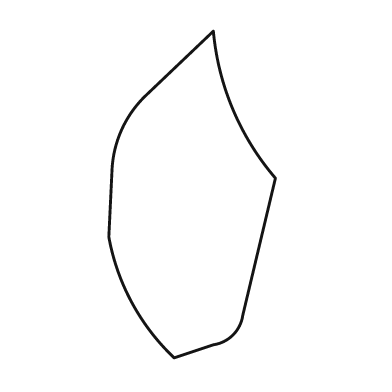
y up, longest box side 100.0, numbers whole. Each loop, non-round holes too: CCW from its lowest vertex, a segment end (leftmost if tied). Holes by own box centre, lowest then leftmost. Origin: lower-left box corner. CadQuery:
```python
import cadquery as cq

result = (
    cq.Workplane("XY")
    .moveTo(20.0, 0.0)
    .lineTo(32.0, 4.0)
    .threePointArc((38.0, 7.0), (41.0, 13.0))
    .lineTo(51.0, 55.0)
    .threePointArc((38.0, 76.0), (32.0, 100.0))
    .lineTo(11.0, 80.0)
    .threePointArc((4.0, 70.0), (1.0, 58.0))
    .lineTo(0.0, 37.0)
    .threePointArc((7.0, 17.0), (20.0, 0.0))
    .close()
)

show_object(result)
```